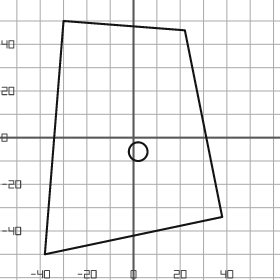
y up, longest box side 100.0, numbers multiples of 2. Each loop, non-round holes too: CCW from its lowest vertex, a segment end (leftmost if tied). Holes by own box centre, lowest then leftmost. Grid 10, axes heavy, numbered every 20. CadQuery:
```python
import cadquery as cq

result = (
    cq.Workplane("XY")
    .moveTo(-38.0, -50.0)
    .lineTo(38.0, -34.0)
    .lineTo(22.0, 46.0)
    .lineTo(-30.0, 50.0)
    .close()
    .moveTo(2.0, -6.0)
    .circle(4.0)
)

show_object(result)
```